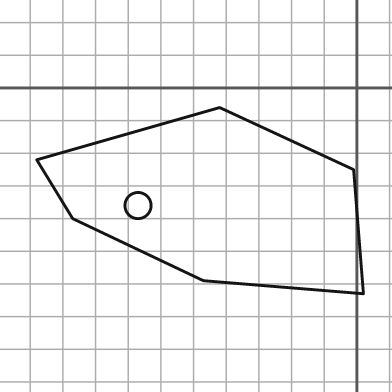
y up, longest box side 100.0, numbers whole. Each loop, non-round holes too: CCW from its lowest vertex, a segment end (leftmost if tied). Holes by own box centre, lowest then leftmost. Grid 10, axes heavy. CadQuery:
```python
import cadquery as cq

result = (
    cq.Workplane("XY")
    .moveTo(2.0, -63.0)
    .lineTo(-1.0, -25.0)
    .lineTo(-42.0, -6.0)
    .lineTo(-98.0, -22.0)
    .lineTo(-87.0, -40.0)
    .lineTo(-47.0, -59.0)
    .close()
    .moveTo(-67.0, -36.0)
    .circle(4.0)
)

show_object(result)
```